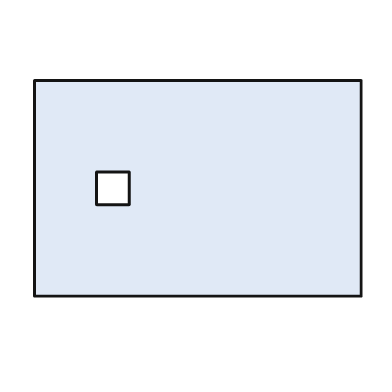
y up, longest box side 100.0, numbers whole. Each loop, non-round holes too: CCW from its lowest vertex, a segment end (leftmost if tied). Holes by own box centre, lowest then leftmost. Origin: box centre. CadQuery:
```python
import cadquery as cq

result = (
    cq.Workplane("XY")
    .moveTo(-50.0, -33.0)
    .lineTo(50.0, -33.0)
    .lineTo(50.0, 33.0)
    .lineTo(-50.0, 33.0)
    .close()
    .moveTo(-31.0, -5.0)
    .lineTo(-21.0, -5.0)
    .lineTo(-21.0, 5.0)
    .lineTo(-31.0, 5.0)
    .close()
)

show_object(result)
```